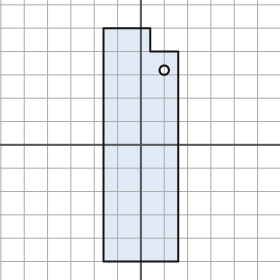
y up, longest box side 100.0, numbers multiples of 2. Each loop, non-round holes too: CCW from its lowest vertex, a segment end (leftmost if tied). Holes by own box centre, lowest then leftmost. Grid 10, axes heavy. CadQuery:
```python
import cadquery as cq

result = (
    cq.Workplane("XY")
    .moveTo(-16.0, -50.0)
    .lineTo(16.0, -50.0)
    .lineTo(16.0, 40.0)
    .lineTo(4.0, 40.0)
    .lineTo(4.0, 50.0)
    .lineTo(-16.0, 50.0)
    .close()
    .moveTo(10.0, 32.0)
    .circle(2.0)
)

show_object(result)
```